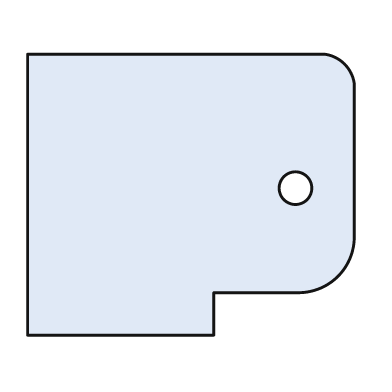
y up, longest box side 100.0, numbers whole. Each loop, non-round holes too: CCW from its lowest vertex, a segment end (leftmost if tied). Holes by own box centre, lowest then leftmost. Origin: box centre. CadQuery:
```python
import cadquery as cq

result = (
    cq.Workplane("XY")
    .moveTo(-50.0, -43.0)
    .lineTo(7.0, -43.0)
    .lineTo(7.0, -30.0)
    .lineTo(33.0, -30.0)
    .threePointArc((45.0, -25.0), (50.0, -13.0))
    .lineTo(50.0, 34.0)
    .threePointArc((47.0, 40.0), (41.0, 43.0))
    .lineTo(-50.0, 43.0)
    .close()
    .moveTo(32.0, 2.0)
    .circle(5.0)
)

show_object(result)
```